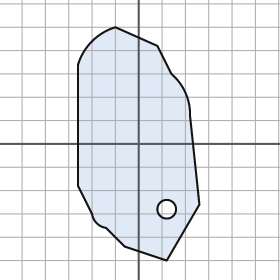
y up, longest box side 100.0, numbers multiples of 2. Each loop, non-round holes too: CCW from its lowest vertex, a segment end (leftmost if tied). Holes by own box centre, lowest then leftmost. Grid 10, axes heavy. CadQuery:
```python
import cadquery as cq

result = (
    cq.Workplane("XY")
    .moveTo(12.0, -50.0)
    .lineTo(26.0, -26.0)
    .lineTo(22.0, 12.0)
    .threePointArc((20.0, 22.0), (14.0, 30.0))
    .lineTo(8.0, 42.0)
    .lineTo(-10.0, 50.0)
    .threePointArc((-20.0, 44.0), (-26.0, 34.0))
    .lineTo(-26.0, -18.0)
    .lineTo(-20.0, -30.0)
    .threePointArc((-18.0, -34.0), (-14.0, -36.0))
    .lineTo(-6.0, -44.0)
    .close()
    .moveTo(12.0, -28.0)
    .circle(4.0)
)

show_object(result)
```